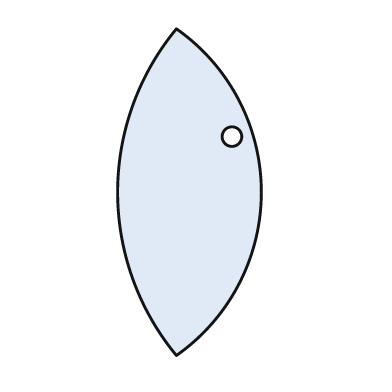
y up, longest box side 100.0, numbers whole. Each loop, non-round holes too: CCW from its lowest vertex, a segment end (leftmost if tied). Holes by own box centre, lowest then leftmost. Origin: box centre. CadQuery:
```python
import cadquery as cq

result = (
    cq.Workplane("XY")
    .moveTo(-4.0, -50.0)
    .threePointArc((22.0, 0.0), (-4.0, 50.0))
    .threePointArc((-22.0, 0.0), (-4.0, -50.0))
    .close()
    .moveTo(13.0, 17.0)
    .circle(3.0)
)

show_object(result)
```